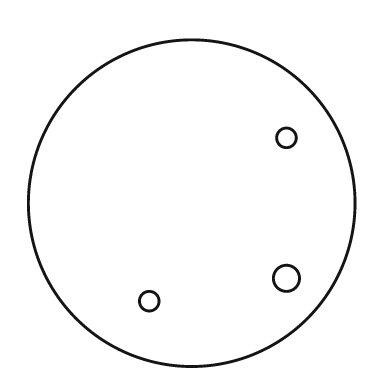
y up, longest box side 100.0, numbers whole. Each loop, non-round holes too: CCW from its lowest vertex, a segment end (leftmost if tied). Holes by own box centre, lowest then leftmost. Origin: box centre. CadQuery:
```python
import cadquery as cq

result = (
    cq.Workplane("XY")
    .moveTo(0.0, 0.0)
    .circle(50.0)
    .moveTo(-13.0, -30.0)
    .circle(3.0)
    .moveTo(29.0, -23.0)
    .circle(4.0)
    .moveTo(29.0, 20.0)
    .circle(3.0)
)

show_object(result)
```